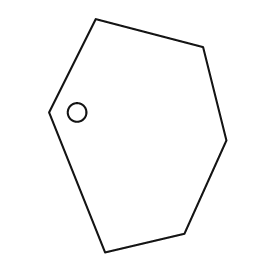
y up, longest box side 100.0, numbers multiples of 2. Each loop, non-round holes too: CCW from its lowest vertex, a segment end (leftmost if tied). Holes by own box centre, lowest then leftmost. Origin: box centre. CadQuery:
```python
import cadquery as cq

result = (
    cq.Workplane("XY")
    .moveTo(-14.0, -50.0)
    .lineTo(20.0, -42.0)
    .lineTo(38.0, -2.0)
    .lineTo(28.0, 38.0)
    .lineTo(-18.0, 50.0)
    .lineTo(-38.0, 10.0)
    .close()
    .moveTo(-26.0, 10.0)
    .circle(4.0)
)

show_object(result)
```